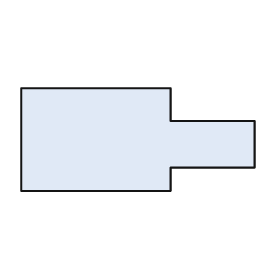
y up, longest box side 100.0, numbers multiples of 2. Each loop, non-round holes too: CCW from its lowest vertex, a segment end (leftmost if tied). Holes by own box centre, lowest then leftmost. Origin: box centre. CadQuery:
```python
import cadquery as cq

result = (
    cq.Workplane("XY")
    .moveTo(-50.0, -22.0)
    .lineTo(14.0, -22.0)
    .lineTo(14.0, -12.0)
    .lineTo(50.0, -12.0)
    .lineTo(50.0, 8.0)
    .lineTo(14.0, 8.0)
    .lineTo(14.0, 22.0)
    .lineTo(-50.0, 22.0)
    .close()
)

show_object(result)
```